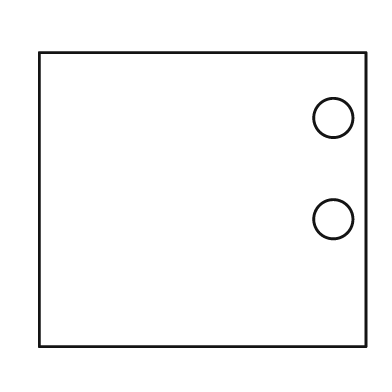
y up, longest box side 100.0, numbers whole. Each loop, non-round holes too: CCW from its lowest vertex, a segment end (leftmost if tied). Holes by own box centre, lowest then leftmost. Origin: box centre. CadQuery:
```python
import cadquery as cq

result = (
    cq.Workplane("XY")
    .moveTo(-50.0, -45.0)
    .lineTo(50.0, -45.0)
    .lineTo(50.0, 45.0)
    .lineTo(-50.0, 45.0)
    .close()
    .moveTo(40.0, -6.0)
    .circle(6.0)
    .moveTo(40.0, 25.0)
    .circle(6.0)
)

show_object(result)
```